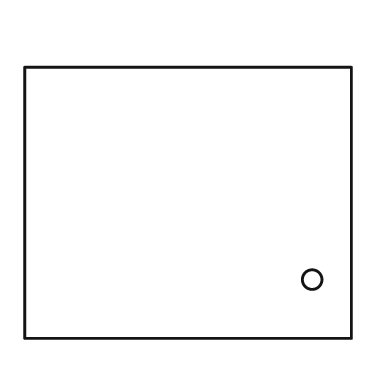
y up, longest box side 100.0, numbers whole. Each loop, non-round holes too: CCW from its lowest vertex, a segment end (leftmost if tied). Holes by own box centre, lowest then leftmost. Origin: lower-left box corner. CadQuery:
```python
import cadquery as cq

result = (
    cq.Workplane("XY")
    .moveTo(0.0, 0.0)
    .lineTo(100.0, 0.0)
    .lineTo(100.0, 83.0)
    .lineTo(0.0, 83.0)
    .close()
    .moveTo(88.0, 18.0)
    .circle(3.0)
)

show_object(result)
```